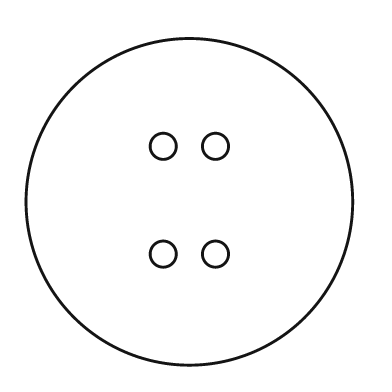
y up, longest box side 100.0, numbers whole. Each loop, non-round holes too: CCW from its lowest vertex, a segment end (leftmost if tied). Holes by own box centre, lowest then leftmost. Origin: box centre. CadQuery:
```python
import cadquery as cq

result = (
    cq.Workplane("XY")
    .moveTo(0.0, 0.0)
    .circle(50.0)
    .moveTo(-8.0, -16.0)
    .circle(4.0)
    .moveTo(8.0, -16.0)
    .circle(4.0)
    .moveTo(-8.0, 17.0)
    .circle(4.0)
    .moveTo(8.0, 17.0)
    .circle(4.0)
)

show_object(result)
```